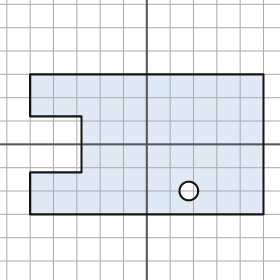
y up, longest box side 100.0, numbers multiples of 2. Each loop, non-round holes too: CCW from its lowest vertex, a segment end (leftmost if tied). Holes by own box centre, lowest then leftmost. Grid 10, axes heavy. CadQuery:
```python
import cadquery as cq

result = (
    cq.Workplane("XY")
    .moveTo(-50.0, -30.0)
    .lineTo(50.0, -30.0)
    .lineTo(50.0, 30.0)
    .lineTo(-50.0, 30.0)
    .lineTo(-50.0, 12.0)
    .lineTo(-28.0, 12.0)
    .lineTo(-28.0, -12.0)
    .lineTo(-50.0, -12.0)
    .close()
    .moveTo(18.0, -20.0)
    .circle(4.0)
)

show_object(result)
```